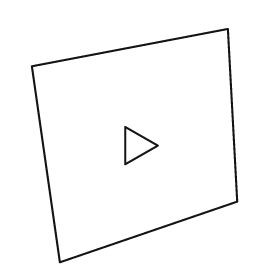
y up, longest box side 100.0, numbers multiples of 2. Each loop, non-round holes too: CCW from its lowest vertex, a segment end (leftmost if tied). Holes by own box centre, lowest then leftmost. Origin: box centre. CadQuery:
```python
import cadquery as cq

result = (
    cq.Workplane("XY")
    .moveTo(-32.0, -50.0)
    .lineTo(44.0, -24.0)
    .lineTo(40.0, 50.0)
    .lineTo(-44.0, 34.0)
    .close()
    .moveTo(-4.0, -8.0)
    .lineTo(10.0, 0.0)
    .lineTo(-4.0, 8.0)
    .close()
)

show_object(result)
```